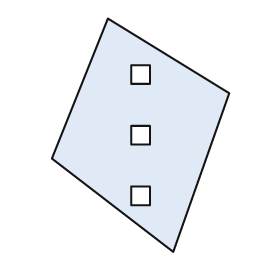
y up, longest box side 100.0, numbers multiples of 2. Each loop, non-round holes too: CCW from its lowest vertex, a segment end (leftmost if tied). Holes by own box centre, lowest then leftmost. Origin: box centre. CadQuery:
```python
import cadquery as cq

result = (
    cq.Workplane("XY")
    .moveTo(14.0, -50.0)
    .lineTo(38.0, 18.0)
    .lineTo(-14.0, 50.0)
    .lineTo(-38.0, -10.0)
    .close()
    .moveTo(-4.0, -30.0)
    .lineTo(4.0, -30.0)
    .lineTo(4.0, -22.0)
    .lineTo(-4.0, -22.0)
    .close()
    .moveTo(-4.0, -4.0)
    .lineTo(4.0, -4.0)
    .lineTo(4.0, 4.0)
    .lineTo(-4.0, 4.0)
    .close()
    .moveTo(-4.0, 22.0)
    .lineTo(4.0, 22.0)
    .lineTo(4.0, 30.0)
    .lineTo(-4.0, 30.0)
    .close()
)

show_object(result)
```